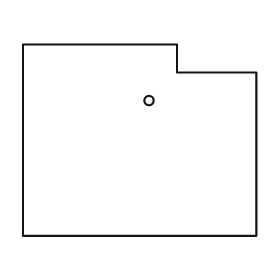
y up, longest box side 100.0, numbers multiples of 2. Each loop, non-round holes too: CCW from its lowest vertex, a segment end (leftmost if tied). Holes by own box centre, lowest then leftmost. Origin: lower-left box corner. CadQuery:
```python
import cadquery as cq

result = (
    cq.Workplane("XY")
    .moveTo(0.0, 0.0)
    .lineTo(100.0, 0.0)
    .lineTo(100.0, 70.0)
    .lineTo(66.0, 70.0)
    .lineTo(66.0, 82.0)
    .lineTo(0.0, 82.0)
    .close()
    .moveTo(54.0, 58.0)
    .circle(2.0)
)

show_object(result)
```